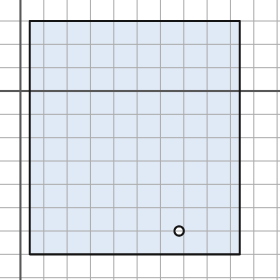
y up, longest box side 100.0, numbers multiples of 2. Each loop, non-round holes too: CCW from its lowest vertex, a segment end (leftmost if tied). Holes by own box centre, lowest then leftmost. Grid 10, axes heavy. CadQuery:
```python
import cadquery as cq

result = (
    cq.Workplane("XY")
    .moveTo(4.0, -70.0)
    .lineTo(94.0, -70.0)
    .lineTo(94.0, 30.0)
    .lineTo(4.0, 30.0)
    .close()
    .moveTo(68.0, -60.0)
    .circle(2.0)
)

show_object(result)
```